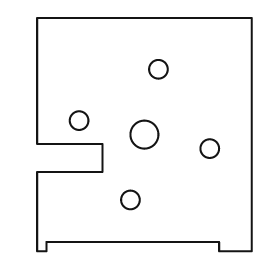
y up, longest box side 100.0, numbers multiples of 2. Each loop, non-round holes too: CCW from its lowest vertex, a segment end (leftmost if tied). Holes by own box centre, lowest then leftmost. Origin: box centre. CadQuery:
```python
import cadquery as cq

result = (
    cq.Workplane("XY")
    .moveTo(-46.0, -50.0)
    .lineTo(-42.0, -50.0)
    .lineTo(-42.0, -46.0)
    .lineTo(32.0, -46.0)
    .lineTo(32.0, -50.0)
    .lineTo(46.0, -50.0)
    .lineTo(46.0, 50.0)
    .lineTo(-46.0, 50.0)
    .lineTo(-46.0, -4.0)
    .lineTo(-18.0, -4.0)
    .lineTo(-18.0, -16.0)
    .lineTo(-46.0, -16.0)
    .close()
    .moveTo(-6.0, -28.0)
    .circle(4.0)
    .moveTo(28.0, -6.0)
    .circle(4.0)
    .moveTo(0.0, 0.0)
    .circle(6.0)
    .moveTo(-28.0, 6.0)
    .circle(4.0)
    .moveTo(6.0, 28.0)
    .circle(4.0)
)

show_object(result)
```